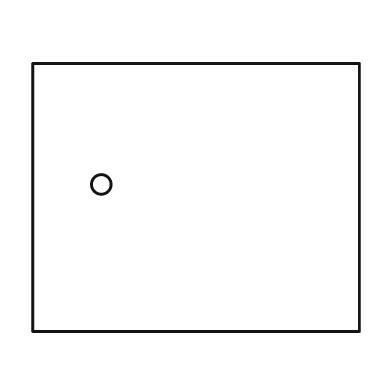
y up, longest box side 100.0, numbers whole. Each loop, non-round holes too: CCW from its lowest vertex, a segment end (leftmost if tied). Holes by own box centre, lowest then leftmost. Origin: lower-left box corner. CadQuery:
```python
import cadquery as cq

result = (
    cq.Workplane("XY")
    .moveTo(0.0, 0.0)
    .lineTo(100.0, 0.0)
    .lineTo(100.0, 82.0)
    .lineTo(0.0, 82.0)
    .close()
    .moveTo(21.0, 45.0)
    .circle(3.0)
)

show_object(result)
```